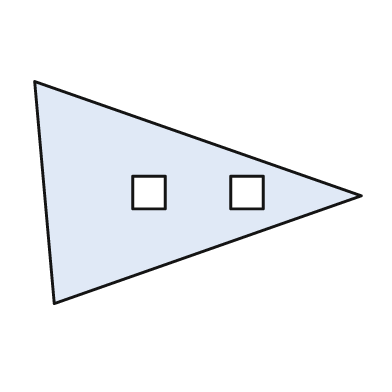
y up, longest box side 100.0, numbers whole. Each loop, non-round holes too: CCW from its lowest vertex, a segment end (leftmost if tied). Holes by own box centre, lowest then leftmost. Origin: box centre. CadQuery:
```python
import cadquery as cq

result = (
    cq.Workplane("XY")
    .moveTo(-44.0, -34.0)
    .lineTo(50.0, -1.0)
    .lineTo(-50.0, 34.0)
    .close()
    .moveTo(-20.0, -5.0)
    .lineTo(-10.0, -5.0)
    .lineTo(-10.0, 5.0)
    .lineTo(-20.0, 5.0)
    .close()
    .moveTo(10.0, -5.0)
    .lineTo(20.0, -5.0)
    .lineTo(20.0, 5.0)
    .lineTo(10.0, 5.0)
    .close()
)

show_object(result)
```